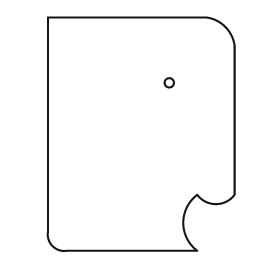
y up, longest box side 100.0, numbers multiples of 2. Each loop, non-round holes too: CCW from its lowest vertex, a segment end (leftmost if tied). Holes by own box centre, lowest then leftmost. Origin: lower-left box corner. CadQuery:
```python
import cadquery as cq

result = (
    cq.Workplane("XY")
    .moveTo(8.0, 0.0)
    .lineTo(64.0, 0.0)
    .threePointArc((58.0, 12.0), (64.0, 24.0))
    .threePointArc((72.0, 20.0), (80.0, 24.0))
    .lineTo(80.0, 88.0)
    .threePointArc((76.0, 96.0), (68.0, 100.0))
    .lineTo(0.0, 100.0)
    .lineTo(0.0, 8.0)
    .threePointArc((2.0, 2.0), (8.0, 0.0))
    .close()
    .moveTo(52.0, 72.0)
    .circle(2.0)
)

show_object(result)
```